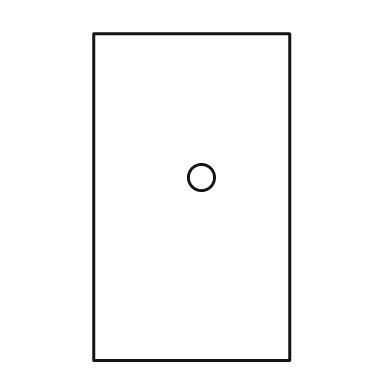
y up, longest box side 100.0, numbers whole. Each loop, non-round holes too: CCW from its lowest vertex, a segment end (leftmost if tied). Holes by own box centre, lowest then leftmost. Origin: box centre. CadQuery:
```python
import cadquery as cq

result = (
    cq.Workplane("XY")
    .moveTo(-30.0, -50.0)
    .lineTo(30.0, -50.0)
    .lineTo(30.0, 50.0)
    .lineTo(-30.0, 50.0)
    .close()
    .moveTo(3.0, 6.0)
    .circle(4.0)
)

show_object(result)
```